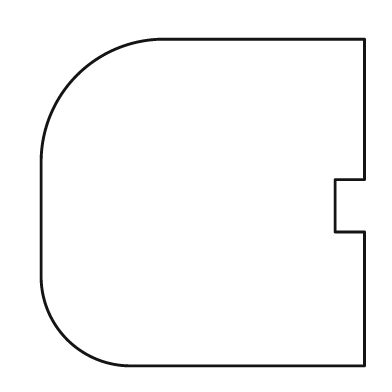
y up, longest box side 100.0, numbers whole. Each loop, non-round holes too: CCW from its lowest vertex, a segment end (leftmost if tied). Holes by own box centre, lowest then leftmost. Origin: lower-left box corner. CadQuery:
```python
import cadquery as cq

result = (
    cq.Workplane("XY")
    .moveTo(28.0, 0.0)
    .lineTo(99.0, 0.0)
    .lineTo(99.0, 41.0)
    .lineTo(90.0, 41.0)
    .lineTo(90.0, 57.0)
    .lineTo(99.0, 57.0)
    .lineTo(99.0, 100.0)
    .lineTo(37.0, 100.0)
    .threePointArc((11.0, 89.0), (0.0, 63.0))
    .lineTo(0.0, 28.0)
    .threePointArc((8.0, 8.0), (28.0, 0.0))
    .close()
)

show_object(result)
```